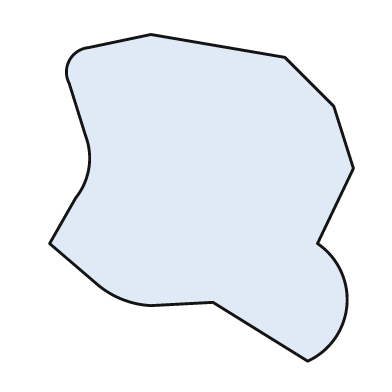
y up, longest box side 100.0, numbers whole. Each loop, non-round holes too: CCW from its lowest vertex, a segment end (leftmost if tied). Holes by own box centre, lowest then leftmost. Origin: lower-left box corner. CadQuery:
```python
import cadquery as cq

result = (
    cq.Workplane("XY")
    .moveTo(79.0, 0.0)
    .threePointArc((91.0, 17.0), (82.0, 36.0))
    .lineTo(93.0, 59.0)
    .lineTo(87.0, 78.0)
    .lineTo(72.0, 93.0)
    .lineTo(31.0, 100.0)
    .lineTo(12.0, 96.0)
    .threePointArc((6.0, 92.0), (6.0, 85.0))
    .lineTo(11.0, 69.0)
    .threePointArc((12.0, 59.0), (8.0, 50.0))
    .lineTo(0.0, 36.0)
    .lineTo(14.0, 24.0)
    .threePointArc((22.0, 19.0), (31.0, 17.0))
    .lineTo(50.0, 18.0)
    .close()
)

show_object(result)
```